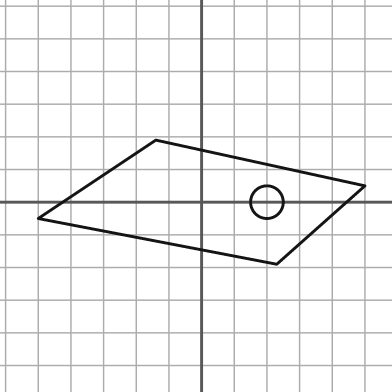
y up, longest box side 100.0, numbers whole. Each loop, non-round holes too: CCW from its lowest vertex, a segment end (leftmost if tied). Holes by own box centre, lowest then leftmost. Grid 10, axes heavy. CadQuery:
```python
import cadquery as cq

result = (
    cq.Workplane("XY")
    .moveTo(23.0, -19.0)
    .lineTo(50.0, 5.0)
    .lineTo(-14.0, 19.0)
    .lineTo(-50.0, -5.0)
    .close()
    .moveTo(20.0, 0.0)
    .circle(5.0)
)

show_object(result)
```